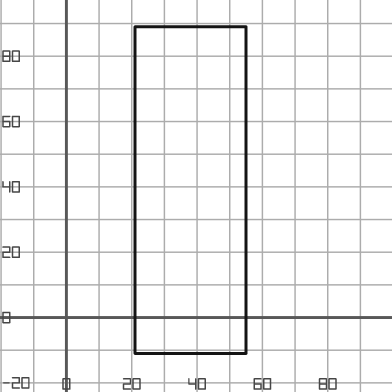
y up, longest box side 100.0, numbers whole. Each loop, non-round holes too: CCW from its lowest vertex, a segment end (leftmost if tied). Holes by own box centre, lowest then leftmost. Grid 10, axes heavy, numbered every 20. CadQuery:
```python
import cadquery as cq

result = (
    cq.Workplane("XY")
    .moveTo(21.0, -11.0)
    .lineTo(55.0, -11.0)
    .lineTo(55.0, 89.0)
    .lineTo(21.0, 89.0)
    .close()
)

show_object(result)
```